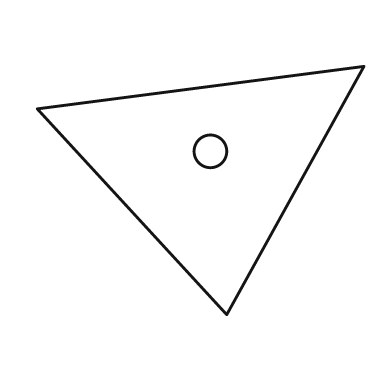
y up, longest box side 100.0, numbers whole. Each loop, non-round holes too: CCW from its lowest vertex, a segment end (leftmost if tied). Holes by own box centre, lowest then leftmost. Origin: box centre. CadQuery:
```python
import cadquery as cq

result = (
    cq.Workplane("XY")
    .moveTo(8.0, -38.0)
    .lineTo(50.0, 38.0)
    .lineTo(-50.0, 25.0)
    .close()
    .moveTo(3.0, 12.0)
    .circle(5.0)
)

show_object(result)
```